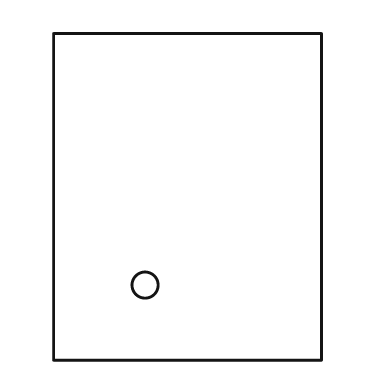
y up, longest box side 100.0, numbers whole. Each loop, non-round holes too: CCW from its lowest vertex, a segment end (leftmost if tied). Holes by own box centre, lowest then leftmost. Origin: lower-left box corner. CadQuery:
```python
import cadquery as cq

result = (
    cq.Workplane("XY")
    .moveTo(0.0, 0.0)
    .lineTo(82.0, 0.0)
    .lineTo(82.0, 100.0)
    .lineTo(0.0, 100.0)
    .close()
    .moveTo(28.0, 23.0)
    .circle(4.0)
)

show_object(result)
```